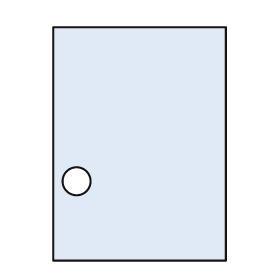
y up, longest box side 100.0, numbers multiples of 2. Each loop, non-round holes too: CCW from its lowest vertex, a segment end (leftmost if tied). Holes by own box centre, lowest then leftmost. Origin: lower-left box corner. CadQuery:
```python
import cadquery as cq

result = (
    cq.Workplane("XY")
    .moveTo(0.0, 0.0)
    .lineTo(74.0, 0.0)
    .lineTo(74.0, 100.0)
    .lineTo(0.0, 100.0)
    .close()
    .moveTo(10.0, 34.0)
    .circle(6.0)
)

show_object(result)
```